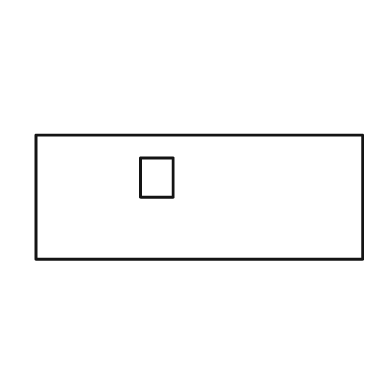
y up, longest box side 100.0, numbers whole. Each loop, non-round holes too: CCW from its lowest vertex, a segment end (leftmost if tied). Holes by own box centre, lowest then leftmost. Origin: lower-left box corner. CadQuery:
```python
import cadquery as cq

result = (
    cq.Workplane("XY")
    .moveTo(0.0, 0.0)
    .lineTo(100.0, 0.0)
    .lineTo(100.0, 38.0)
    .lineTo(0.0, 38.0)
    .close()
    .moveTo(32.0, 19.0)
    .lineTo(42.0, 19.0)
    .lineTo(42.0, 31.0)
    .lineTo(32.0, 31.0)
    .close()
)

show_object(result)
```